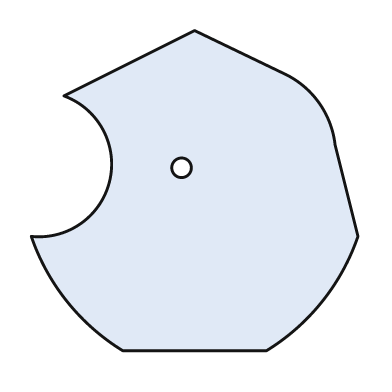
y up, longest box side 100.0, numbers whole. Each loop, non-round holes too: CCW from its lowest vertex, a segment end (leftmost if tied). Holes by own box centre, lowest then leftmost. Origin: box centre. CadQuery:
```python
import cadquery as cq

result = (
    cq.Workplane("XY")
    .moveTo(-22.0, -49.0)
    .lineTo(22.0, -49.0)
    .threePointArc((39.0, -34.0), (50.0, -14.0))
    .lineTo(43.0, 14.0)
    .threePointArc((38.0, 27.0), (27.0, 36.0))
    .lineTo(0.0, 49.0)
    .lineTo(-40.0, 29.0)
    .threePointArc((-26.0, 3.0), (-50.0, -14.0))
    .threePointArc((-39.0, -34.0), (-22.0, -49.0))
    .close()
    .moveTo(-4.0, 7.0)
    .circle(3.0)
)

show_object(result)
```